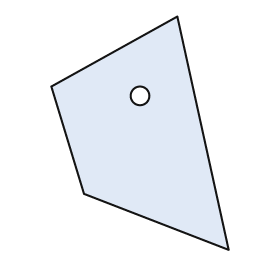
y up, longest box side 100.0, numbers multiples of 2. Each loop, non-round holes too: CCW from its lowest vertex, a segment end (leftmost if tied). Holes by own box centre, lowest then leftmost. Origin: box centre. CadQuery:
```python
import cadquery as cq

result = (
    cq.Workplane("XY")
    .moveTo(38.0, -50.0)
    .lineTo(16.0, 50.0)
    .lineTo(-38.0, 20.0)
    .lineTo(-24.0, -26.0)
    .close()
    .moveTo(0.0, 16.0)
    .circle(4.0)
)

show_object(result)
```